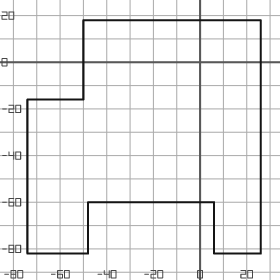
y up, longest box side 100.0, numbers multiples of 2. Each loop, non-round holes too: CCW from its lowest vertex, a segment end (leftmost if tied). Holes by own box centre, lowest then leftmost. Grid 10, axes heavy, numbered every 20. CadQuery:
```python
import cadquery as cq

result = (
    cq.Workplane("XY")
    .moveTo(-74.0, -82.0)
    .lineTo(-48.0, -82.0)
    .lineTo(-48.0, -60.0)
    .lineTo(6.0, -60.0)
    .lineTo(6.0, -82.0)
    .lineTo(26.0, -82.0)
    .lineTo(26.0, 18.0)
    .lineTo(-50.0, 18.0)
    .lineTo(-50.0, -16.0)
    .lineTo(-74.0, -16.0)
    .close()
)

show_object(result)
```